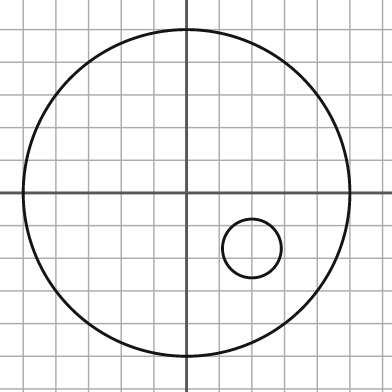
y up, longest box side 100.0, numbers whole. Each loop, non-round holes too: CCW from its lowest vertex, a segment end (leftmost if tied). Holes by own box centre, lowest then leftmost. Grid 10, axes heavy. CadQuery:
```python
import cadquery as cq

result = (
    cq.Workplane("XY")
    .moveTo(0.0, 0.0)
    .circle(50.0)
    .moveTo(20.0, -17.0)
    .circle(9.0)
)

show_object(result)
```